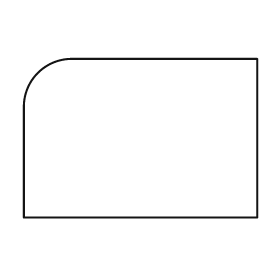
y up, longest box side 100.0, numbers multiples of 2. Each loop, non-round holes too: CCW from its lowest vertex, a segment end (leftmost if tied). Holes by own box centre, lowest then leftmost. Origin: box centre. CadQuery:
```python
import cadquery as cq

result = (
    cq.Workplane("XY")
    .moveTo(-50.0, -34.0)
    .lineTo(50.0, -34.0)
    .lineTo(50.0, 34.0)
    .lineTo(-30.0, 34.0)
    .threePointArc((-44.0, 28.0), (-50.0, 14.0))
    .close()
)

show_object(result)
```